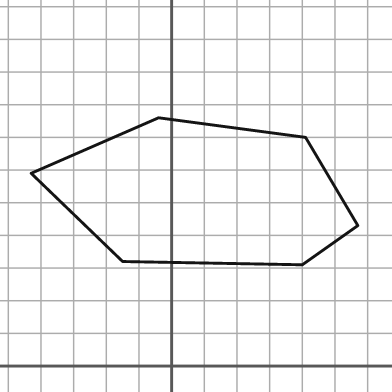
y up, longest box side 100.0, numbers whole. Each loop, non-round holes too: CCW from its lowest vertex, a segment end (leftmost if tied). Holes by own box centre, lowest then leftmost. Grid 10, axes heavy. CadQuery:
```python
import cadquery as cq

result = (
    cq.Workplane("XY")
    .moveTo(40.0, 31.0)
    .lineTo(57.0, 43.0)
    .lineTo(41.0, 70.0)
    .lineTo(-4.0, 76.0)
    .lineTo(-43.0, 59.0)
    .lineTo(-15.0, 32.0)
    .close()
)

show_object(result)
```